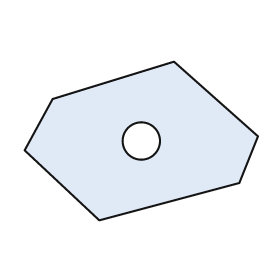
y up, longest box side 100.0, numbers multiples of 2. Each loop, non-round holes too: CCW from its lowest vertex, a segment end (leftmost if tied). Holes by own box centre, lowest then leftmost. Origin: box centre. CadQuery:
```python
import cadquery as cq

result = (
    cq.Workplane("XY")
    .moveTo(-18.0, -34.0)
    .lineTo(42.0, -18.0)
    .lineTo(50.0, 2.0)
    .lineTo(14.0, 34.0)
    .lineTo(-38.0, 18.0)
    .lineTo(-50.0, -4.0)
    .close()
    .moveTo(0.0, 0.0)
    .circle(8.0)
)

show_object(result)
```